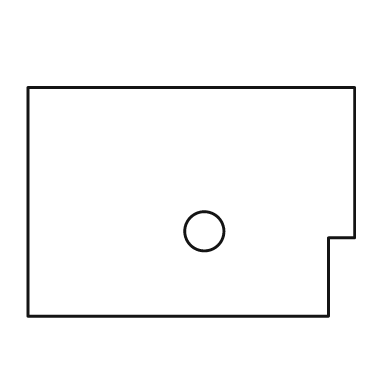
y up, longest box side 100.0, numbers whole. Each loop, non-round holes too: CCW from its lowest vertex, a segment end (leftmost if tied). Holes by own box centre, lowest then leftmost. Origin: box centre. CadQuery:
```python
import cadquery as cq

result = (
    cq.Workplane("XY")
    .moveTo(-50.0, -35.0)
    .lineTo(42.0, -35.0)
    .lineTo(42.0, -11.0)
    .lineTo(50.0, -11.0)
    .lineTo(50.0, 35.0)
    .lineTo(-50.0, 35.0)
    .close()
    .moveTo(4.0, -9.0)
    .circle(6.0)
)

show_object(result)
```